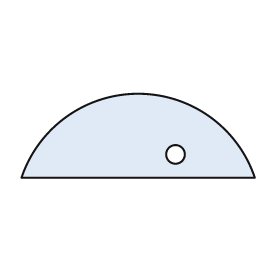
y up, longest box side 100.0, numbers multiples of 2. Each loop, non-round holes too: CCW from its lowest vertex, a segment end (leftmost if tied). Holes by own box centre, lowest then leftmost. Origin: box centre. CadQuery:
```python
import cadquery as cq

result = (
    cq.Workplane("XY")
    .moveTo(-50.0, -18.0)
    .lineTo(50.0, -18.0)
    .threePointArc((0.0, 18.0), (-50.0, -18.0))
    .close()
    .moveTo(16.0, -8.0)
    .circle(4.0)
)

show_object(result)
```